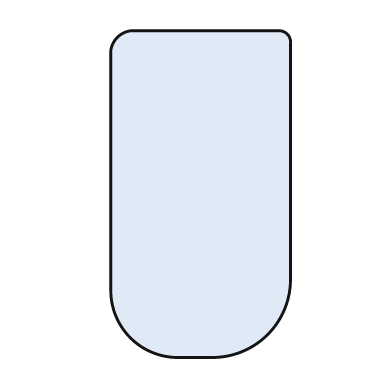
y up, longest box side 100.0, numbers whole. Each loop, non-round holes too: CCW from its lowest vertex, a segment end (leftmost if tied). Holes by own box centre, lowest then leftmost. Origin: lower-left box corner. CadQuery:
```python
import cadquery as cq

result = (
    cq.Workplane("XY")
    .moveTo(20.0, 0.0)
    .lineTo(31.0, 0.0)
    .threePointArc((48.0, 7.0), (55.0, 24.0))
    .lineTo(55.0, 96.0)
    .threePointArc((54.0, 99.0), (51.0, 100.0))
    .lineTo(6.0, 100.0)
    .threePointArc((2.0, 98.0), (0.0, 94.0))
    .lineTo(0.0, 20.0)
    .threePointArc((6.0, 6.0), (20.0, 0.0))
    .close()
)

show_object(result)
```